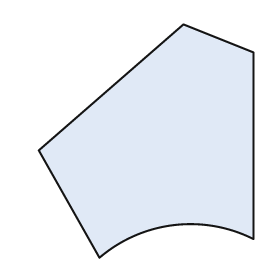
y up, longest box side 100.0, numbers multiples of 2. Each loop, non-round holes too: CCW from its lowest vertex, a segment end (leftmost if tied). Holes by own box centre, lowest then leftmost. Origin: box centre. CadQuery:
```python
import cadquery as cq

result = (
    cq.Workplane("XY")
    .moveTo(-20.0, -50.0)
    .threePointArc((12.0, -36.0), (46.0, -42.0))
    .lineTo(46.0, 38.0)
    .lineTo(16.0, 50.0)
    .lineTo(-46.0, -4.0)
    .close()
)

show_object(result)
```